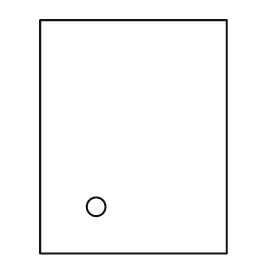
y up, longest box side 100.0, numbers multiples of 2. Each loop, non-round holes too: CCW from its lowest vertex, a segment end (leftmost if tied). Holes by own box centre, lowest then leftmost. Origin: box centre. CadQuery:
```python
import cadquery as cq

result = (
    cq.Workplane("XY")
    .moveTo(-40.0, -50.0)
    .lineTo(40.0, -50.0)
    .lineTo(40.0, 50.0)
    .lineTo(-40.0, 50.0)
    .close()
    .moveTo(-16.0, -30.0)
    .circle(4.0)
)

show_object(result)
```